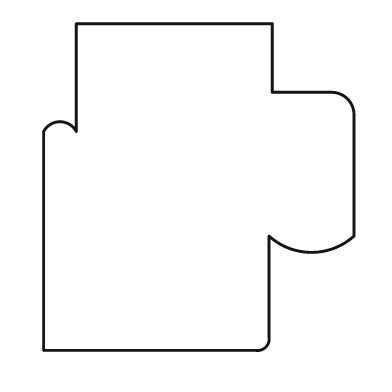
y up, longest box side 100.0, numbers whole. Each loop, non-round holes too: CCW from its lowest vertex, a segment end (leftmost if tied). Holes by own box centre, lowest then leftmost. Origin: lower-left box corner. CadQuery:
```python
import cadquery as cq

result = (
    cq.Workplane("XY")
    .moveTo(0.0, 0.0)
    .lineTo(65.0, 0.0)
    .threePointArc((68.0, 1.0), (69.0, 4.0))
    .lineTo(69.0, 35.0)
    .threePointArc((82.0, 30.0), (95.0, 35.0))
    .lineTo(95.0, 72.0)
    .threePointArc((93.0, 77.0), (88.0, 79.0))
    .lineTo(70.0, 79.0)
    .lineTo(70.0, 100.0)
    .lineTo(10.0, 100.0)
    .lineTo(10.0, 67.0)
    .threePointArc((5.0, 70.0), (0.0, 67.0))
    .close()
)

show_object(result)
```